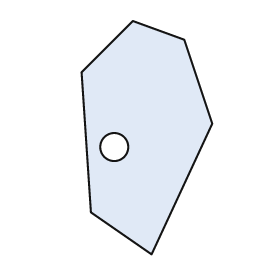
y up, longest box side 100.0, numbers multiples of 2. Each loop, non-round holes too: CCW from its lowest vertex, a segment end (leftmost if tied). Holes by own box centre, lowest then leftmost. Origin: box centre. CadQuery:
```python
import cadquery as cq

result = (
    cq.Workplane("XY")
    .moveTo(2.0, -50.0)
    .lineTo(28.0, 6.0)
    .lineTo(16.0, 42.0)
    .lineTo(-6.0, 50.0)
    .lineTo(-28.0, 28.0)
    .lineTo(-24.0, -32.0)
    .close()
    .moveTo(-14.0, -4.0)
    .circle(6.0)
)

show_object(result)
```